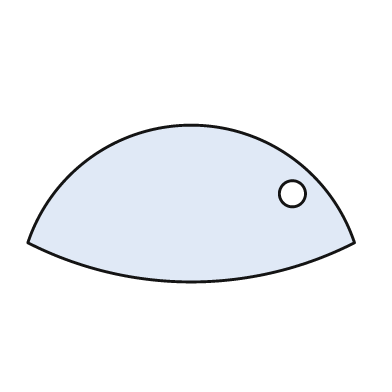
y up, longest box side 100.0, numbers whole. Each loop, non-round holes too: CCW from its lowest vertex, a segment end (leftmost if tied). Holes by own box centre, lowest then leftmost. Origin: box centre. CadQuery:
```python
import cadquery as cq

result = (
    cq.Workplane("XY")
    .moveTo(-50.0, -12.0)
    .threePointArc((0.0, -24.0), (50.0, -12.0))
    .threePointArc((0.0, 24.0), (-50.0, -12.0))
    .close()
    .moveTo(31.0, 3.0)
    .circle(4.0)
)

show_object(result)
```